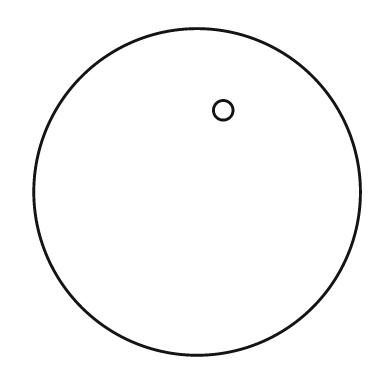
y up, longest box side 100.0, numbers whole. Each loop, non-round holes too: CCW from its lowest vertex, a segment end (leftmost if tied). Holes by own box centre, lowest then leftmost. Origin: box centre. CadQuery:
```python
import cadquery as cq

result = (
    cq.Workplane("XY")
    .moveTo(0.0, 0.0)
    .circle(50.0)
    .moveTo(8.0, 25.0)
    .circle(3.0)
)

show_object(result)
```